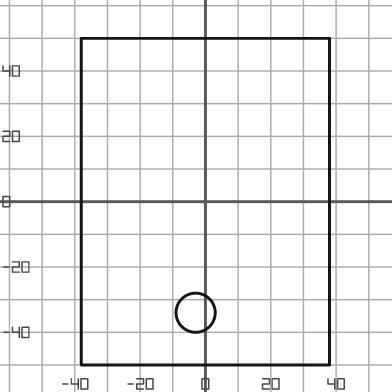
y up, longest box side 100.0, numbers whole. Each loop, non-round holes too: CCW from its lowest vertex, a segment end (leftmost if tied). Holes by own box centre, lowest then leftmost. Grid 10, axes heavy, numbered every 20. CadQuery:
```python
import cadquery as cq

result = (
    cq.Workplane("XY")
    .moveTo(-38.0, -50.0)
    .lineTo(38.0, -50.0)
    .lineTo(38.0, 50.0)
    .lineTo(-38.0, 50.0)
    .close()
    .moveTo(-3.0, -34.0)
    .circle(6.0)
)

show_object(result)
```